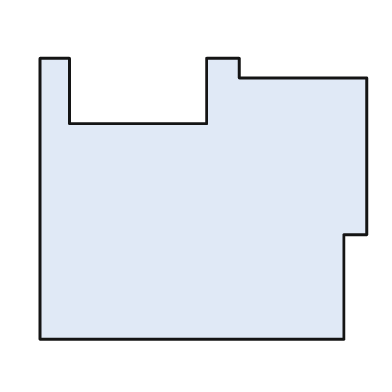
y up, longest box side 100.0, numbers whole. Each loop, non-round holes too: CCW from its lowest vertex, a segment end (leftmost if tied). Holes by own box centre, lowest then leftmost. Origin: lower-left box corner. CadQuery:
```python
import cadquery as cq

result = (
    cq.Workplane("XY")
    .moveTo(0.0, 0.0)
    .lineTo(93.0, 0.0)
    .lineTo(93.0, 32.0)
    .lineTo(100.0, 32.0)
    .lineTo(100.0, 80.0)
    .lineTo(61.0, 80.0)
    .lineTo(61.0, 86.0)
    .lineTo(51.0, 86.0)
    .lineTo(51.0, 66.0)
    .lineTo(9.0, 66.0)
    .lineTo(9.0, 86.0)
    .lineTo(0.0, 86.0)
    .close()
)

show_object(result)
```